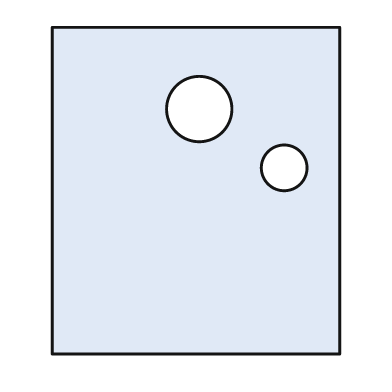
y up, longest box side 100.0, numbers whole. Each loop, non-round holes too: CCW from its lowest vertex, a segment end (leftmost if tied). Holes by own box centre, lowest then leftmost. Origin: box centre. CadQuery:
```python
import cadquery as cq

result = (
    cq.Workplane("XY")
    .moveTo(-44.0, -50.0)
    .lineTo(44.0, -50.0)
    .lineTo(44.0, 50.0)
    .lineTo(-44.0, 50.0)
    .close()
    .moveTo(27.0, 7.0)
    .circle(7.0)
    .moveTo(1.0, 25.0)
    .circle(10.0)
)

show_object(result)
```